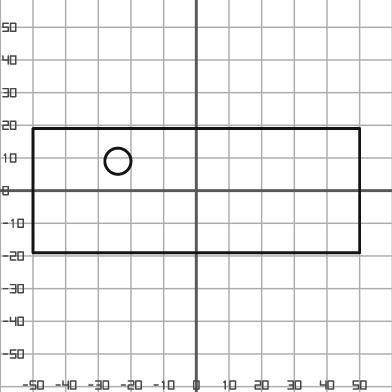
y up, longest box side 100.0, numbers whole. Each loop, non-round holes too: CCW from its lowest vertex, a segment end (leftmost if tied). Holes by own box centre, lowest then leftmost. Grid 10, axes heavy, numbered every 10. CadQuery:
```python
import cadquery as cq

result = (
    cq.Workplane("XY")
    .moveTo(-50.0, -19.0)
    .lineTo(50.0, -19.0)
    .lineTo(50.0, 19.0)
    .lineTo(-50.0, 19.0)
    .close()
    .moveTo(-24.0, 9.0)
    .circle(4.0)
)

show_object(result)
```